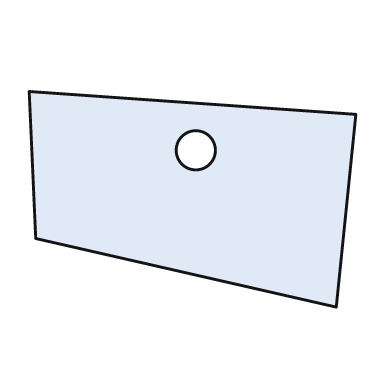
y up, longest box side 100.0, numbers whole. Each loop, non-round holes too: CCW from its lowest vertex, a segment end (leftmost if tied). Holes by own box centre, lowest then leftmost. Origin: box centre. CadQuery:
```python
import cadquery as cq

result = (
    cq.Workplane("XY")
    .moveTo(44.0, -33.0)
    .lineTo(50.0, 26.0)
    .lineTo(-50.0, 33.0)
    .lineTo(-48.0, -12.0)
    .close()
    .moveTo(1.0, 15.0)
    .circle(6.0)
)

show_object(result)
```